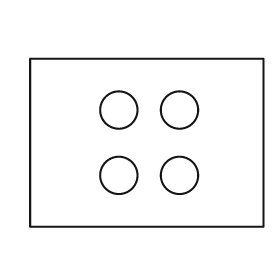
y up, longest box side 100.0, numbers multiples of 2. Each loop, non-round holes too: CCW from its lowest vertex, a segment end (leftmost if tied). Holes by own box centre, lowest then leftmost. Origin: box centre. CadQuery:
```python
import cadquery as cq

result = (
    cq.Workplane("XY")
    .moveTo(-50.0, -36.0)
    .lineTo(50.0, -36.0)
    .lineTo(50.0, 36.0)
    .lineTo(-50.0, 36.0)
    .close()
    .moveTo(-12.0, -14.0)
    .circle(8.0)
    .moveTo(14.0, -14.0)
    .circle(8.0)
    .moveTo(-12.0, 14.0)
    .circle(8.0)
    .moveTo(14.0, 14.0)
    .circle(8.0)
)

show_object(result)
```